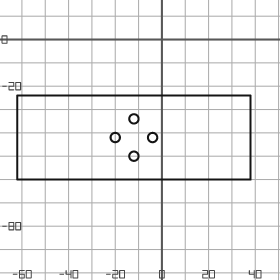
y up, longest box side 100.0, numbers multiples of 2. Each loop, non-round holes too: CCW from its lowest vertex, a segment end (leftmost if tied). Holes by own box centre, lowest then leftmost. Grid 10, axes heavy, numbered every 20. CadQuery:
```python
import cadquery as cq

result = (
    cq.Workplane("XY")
    .moveTo(-62.0, -60.0)
    .lineTo(38.0, -60.0)
    .lineTo(38.0, -24.0)
    .lineTo(-62.0, -24.0)
    .close()
    .moveTo(-12.0, -50.0)
    .circle(2.0)
    .moveTo(-20.0, -42.0)
    .circle(2.0)
    .moveTo(-4.0, -42.0)
    .circle(2.0)
    .moveTo(-12.0, -34.0)
    .circle(2.0)
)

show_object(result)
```